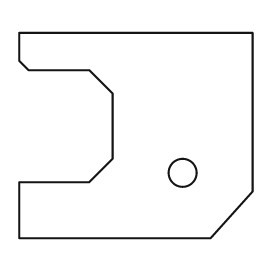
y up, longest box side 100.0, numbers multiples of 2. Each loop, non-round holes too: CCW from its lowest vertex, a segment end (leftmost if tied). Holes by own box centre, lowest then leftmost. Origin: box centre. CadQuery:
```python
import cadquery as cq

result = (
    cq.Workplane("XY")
    .moveTo(-50.0, -44.0)
    .lineTo(32.0, -44.0)
    .lineTo(50.0, -24.0)
    .lineTo(50.0, 44.0)
    .lineTo(-50.0, 44.0)
    .lineTo(-50.0, 32.0)
    .lineTo(-46.0, 28.0)
    .lineTo(-20.0, 28.0)
    .lineTo(-10.0, 18.0)
    .lineTo(-10.0, -10.0)
    .lineTo(-20.0, -20.0)
    .lineTo(-50.0, -20.0)
    .close()
    .moveTo(20.0, -16.0)
    .circle(6.0)
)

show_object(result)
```